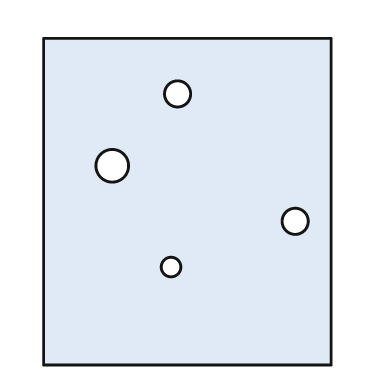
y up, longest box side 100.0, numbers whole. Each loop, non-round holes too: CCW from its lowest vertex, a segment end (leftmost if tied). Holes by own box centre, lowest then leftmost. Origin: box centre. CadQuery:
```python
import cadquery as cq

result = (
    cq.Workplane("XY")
    .moveTo(-44.0, -50.0)
    .lineTo(44.0, -50.0)
    .lineTo(44.0, 50.0)
    .lineTo(-44.0, 50.0)
    .close()
    .moveTo(-5.0, -20.0)
    .circle(3.0)
    .moveTo(33.0, -6.0)
    .circle(4.0)
    .moveTo(-23.0, 11.0)
    .circle(5.0)
    .moveTo(-3.0, 33.0)
    .circle(4.0)
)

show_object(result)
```